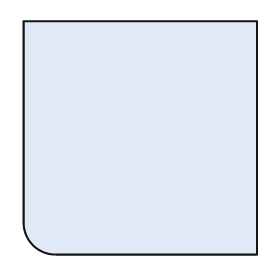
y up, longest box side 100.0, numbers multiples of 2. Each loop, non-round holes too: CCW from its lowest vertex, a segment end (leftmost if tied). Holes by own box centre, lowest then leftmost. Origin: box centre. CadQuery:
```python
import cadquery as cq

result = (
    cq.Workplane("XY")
    .moveTo(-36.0, -50.0)
    .lineTo(50.0, -50.0)
    .lineTo(50.0, 50.0)
    .lineTo(-50.0, 50.0)
    .lineTo(-50.0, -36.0)
    .threePointArc((-46.0, -46.0), (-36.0, -50.0))
    .close()
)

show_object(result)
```